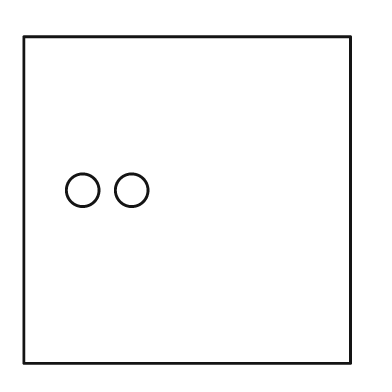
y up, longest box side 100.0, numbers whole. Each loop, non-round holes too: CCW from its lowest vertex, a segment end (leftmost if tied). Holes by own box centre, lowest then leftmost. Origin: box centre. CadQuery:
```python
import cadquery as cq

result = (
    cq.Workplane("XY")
    .moveTo(-50.0, -50.0)
    .lineTo(50.0, -50.0)
    .lineTo(50.0, 50.0)
    .lineTo(-50.0, 50.0)
    .close()
    .moveTo(-32.0, 3.0)
    .circle(5.0)
    .moveTo(-17.0, 3.0)
    .circle(5.0)
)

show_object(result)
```